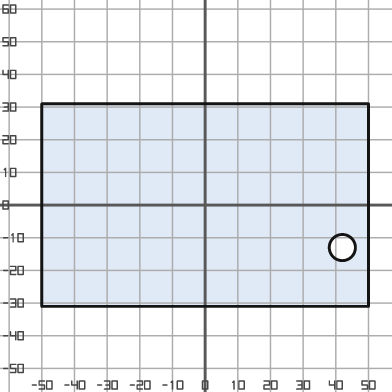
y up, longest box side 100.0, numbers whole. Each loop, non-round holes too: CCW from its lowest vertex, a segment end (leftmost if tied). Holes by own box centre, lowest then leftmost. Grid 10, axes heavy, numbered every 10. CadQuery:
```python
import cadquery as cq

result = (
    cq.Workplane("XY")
    .moveTo(-50.0, -31.0)
    .lineTo(50.0, -31.0)
    .lineTo(50.0, 31.0)
    .lineTo(-50.0, 31.0)
    .close()
    .moveTo(42.0, -13.0)
    .circle(4.0)
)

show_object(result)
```